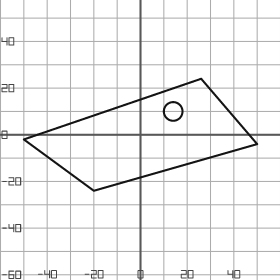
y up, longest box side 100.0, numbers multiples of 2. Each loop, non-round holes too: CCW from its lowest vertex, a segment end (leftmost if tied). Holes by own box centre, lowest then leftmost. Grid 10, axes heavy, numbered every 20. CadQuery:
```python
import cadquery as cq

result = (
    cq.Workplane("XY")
    .moveTo(-20.0, -24.0)
    .lineTo(50.0, -4.0)
    .lineTo(26.0, 24.0)
    .lineTo(-50.0, -2.0)
    .close()
    .moveTo(14.0, 10.0)
    .circle(4.0)
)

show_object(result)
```